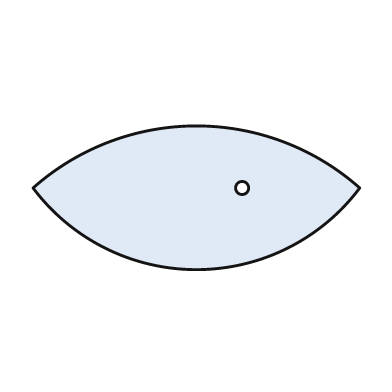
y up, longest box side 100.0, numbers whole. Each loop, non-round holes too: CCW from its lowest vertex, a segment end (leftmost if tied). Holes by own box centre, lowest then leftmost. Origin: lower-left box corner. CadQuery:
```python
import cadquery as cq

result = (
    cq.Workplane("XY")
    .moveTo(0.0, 25.0)
    .threePointArc((50.0, 0.0), (100.0, 25.0))
    .threePointArc((50.0, 44.0), (0.0, 25.0))
    .close()
    .moveTo(64.0, 25.0)
    .circle(2.0)
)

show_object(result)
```